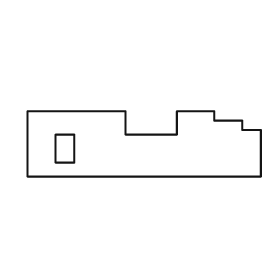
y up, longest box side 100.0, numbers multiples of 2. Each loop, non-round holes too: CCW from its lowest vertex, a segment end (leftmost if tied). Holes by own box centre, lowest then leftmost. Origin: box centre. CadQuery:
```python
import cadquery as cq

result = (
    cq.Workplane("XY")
    .moveTo(-50.0, -14.0)
    .lineTo(50.0, -14.0)
    .lineTo(50.0, 6.0)
    .lineTo(42.0, 6.0)
    .lineTo(42.0, 10.0)
    .lineTo(30.0, 10.0)
    .lineTo(30.0, 14.0)
    .lineTo(14.0, 14.0)
    .lineTo(14.0, 4.0)
    .lineTo(-8.0, 4.0)
    .lineTo(-8.0, 14.0)
    .lineTo(-50.0, 14.0)
    .close()
    .moveTo(-38.0, -8.0)
    .lineTo(-30.0, -8.0)
    .lineTo(-30.0, 4.0)
    .lineTo(-38.0, 4.0)
    .close()
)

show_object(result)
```